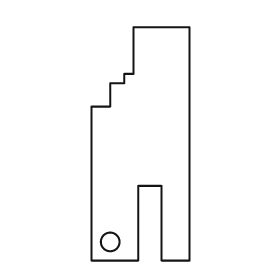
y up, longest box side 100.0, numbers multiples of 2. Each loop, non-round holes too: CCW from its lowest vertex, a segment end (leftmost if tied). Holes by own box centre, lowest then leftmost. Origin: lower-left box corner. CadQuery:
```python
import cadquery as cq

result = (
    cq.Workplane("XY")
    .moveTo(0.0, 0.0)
    .lineTo(20.0, 0.0)
    .lineTo(20.0, 32.0)
    .lineTo(30.0, 32.0)
    .lineTo(30.0, 0.0)
    .lineTo(42.0, 0.0)
    .lineTo(42.0, 100.0)
    .lineTo(18.0, 100.0)
    .lineTo(18.0, 80.0)
    .lineTo(14.0, 80.0)
    .lineTo(14.0, 76.0)
    .lineTo(8.0, 76.0)
    .lineTo(8.0, 66.0)
    .lineTo(0.0, 66.0)
    .close()
    .moveTo(8.0, 8.0)
    .circle(4.0)
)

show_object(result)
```